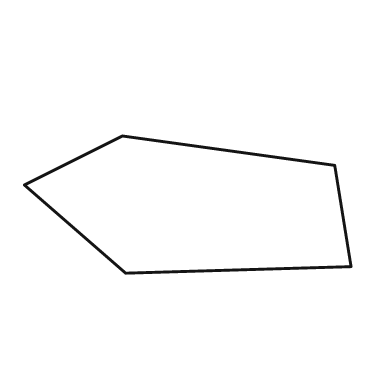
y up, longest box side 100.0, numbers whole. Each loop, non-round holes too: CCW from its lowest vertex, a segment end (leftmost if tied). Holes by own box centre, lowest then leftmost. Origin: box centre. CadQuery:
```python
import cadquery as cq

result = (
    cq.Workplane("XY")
    .moveTo(-19.0, -21.0)
    .lineTo(50.0, -19.0)
    .lineTo(45.0, 12.0)
    .lineTo(-20.0, 21.0)
    .lineTo(-50.0, 6.0)
    .close()
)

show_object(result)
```